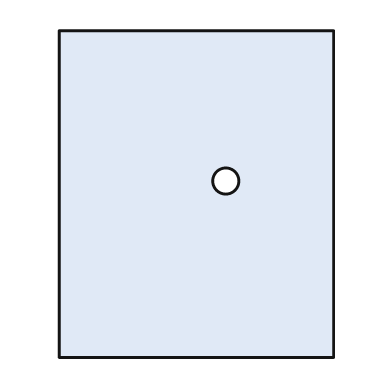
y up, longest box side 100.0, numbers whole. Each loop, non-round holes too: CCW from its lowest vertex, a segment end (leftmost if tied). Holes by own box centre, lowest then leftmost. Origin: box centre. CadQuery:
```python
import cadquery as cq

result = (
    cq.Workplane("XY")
    .moveTo(-42.0, -50.0)
    .lineTo(42.0, -50.0)
    .lineTo(42.0, 50.0)
    .lineTo(-42.0, 50.0)
    .close()
    .moveTo(9.0, 4.0)
    .circle(4.0)
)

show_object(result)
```